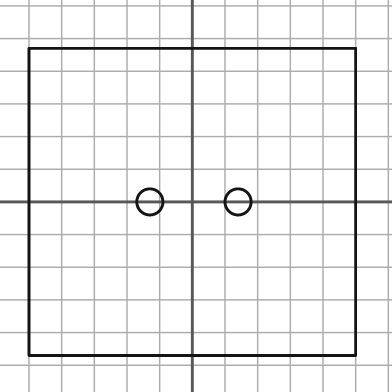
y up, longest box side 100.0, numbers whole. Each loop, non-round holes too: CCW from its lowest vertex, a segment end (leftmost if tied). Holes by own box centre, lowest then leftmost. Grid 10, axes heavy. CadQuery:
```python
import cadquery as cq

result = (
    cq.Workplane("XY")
    .moveTo(-50.0, -47.0)
    .lineTo(50.0, -47.0)
    .lineTo(50.0, 47.0)
    .lineTo(-50.0, 47.0)
    .close()
    .moveTo(-13.0, 0.0)
    .circle(4.0)
    .moveTo(14.0, 0.0)
    .circle(4.0)
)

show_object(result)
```